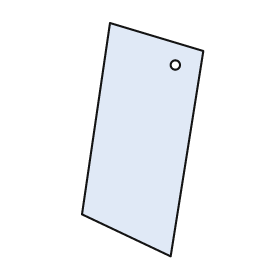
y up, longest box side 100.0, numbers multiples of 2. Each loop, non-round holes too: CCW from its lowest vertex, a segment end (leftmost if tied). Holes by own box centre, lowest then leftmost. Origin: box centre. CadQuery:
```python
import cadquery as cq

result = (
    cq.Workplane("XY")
    .moveTo(12.0, -50.0)
    .lineTo(26.0, 38.0)
    .lineTo(-14.0, 50.0)
    .lineTo(-26.0, -32.0)
    .close()
    .moveTo(14.0, 32.0)
    .circle(2.0)
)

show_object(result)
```